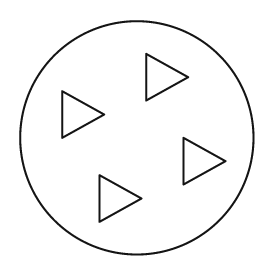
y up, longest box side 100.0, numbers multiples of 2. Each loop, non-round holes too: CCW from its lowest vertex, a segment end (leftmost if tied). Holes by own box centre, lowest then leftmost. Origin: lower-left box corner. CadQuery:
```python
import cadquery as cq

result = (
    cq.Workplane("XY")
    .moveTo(50.0, 50.0)
    .circle(50.0)
    .moveTo(34.0, 14.0)
    .lineTo(52.0, 24.0)
    .lineTo(34.0, 34.0)
    .close()
    .moveTo(70.0, 30.0)
    .lineTo(88.0, 40.0)
    .lineTo(70.0, 50.0)
    .close()
    .moveTo(18.0, 50.0)
    .lineTo(36.0, 60.0)
    .lineTo(18.0, 70.0)
    .close()
    .moveTo(54.0, 66.0)
    .lineTo(72.0, 76.0)
    .lineTo(54.0, 86.0)
    .close()
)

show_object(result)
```